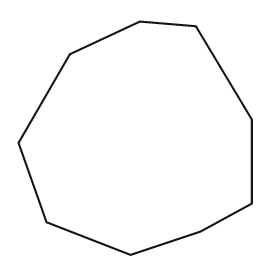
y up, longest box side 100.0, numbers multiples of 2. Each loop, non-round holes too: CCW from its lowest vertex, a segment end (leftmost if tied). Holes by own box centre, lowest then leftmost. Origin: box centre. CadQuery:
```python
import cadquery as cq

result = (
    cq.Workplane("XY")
    .moveTo(-2.0, -50.0)
    .lineTo(28.0, -40.0)
    .lineTo(50.0, -28.0)
    .lineTo(50.0, 8.0)
    .lineTo(26.0, 48.0)
    .lineTo(2.0, 50.0)
    .lineTo(-28.0, 36.0)
    .lineTo(-50.0, -2.0)
    .lineTo(-38.0, -36.0)
    .close()
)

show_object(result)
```